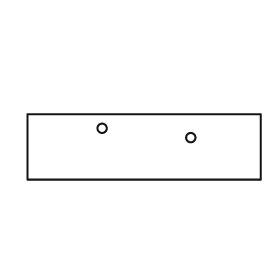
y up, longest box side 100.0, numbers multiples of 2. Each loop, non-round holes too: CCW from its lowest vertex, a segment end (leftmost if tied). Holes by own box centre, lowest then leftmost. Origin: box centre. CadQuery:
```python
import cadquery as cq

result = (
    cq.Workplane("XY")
    .moveTo(-50.0, -14.0)
    .lineTo(50.0, -14.0)
    .lineTo(50.0, 14.0)
    .lineTo(-50.0, 14.0)
    .close()
    .moveTo(20.0, 4.0)
    .circle(2.0)
    .moveTo(-18.0, 8.0)
    .circle(2.0)
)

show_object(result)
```